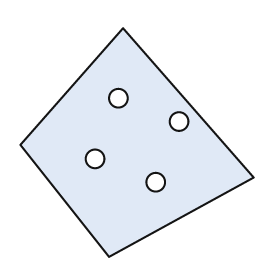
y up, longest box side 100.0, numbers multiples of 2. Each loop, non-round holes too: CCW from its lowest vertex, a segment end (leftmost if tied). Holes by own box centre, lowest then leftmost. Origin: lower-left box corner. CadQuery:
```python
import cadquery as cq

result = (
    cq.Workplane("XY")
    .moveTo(38.0, 0.0)
    .lineTo(100.0, 34.0)
    .lineTo(44.0, 98.0)
    .lineTo(0.0, 48.0)
    .close()
    .moveTo(58.0, 32.0)
    .circle(4.0)
    .moveTo(32.0, 42.0)
    .circle(4.0)
    .moveTo(68.0, 58.0)
    .circle(4.0)
    .moveTo(42.0, 68.0)
    .circle(4.0)
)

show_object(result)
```